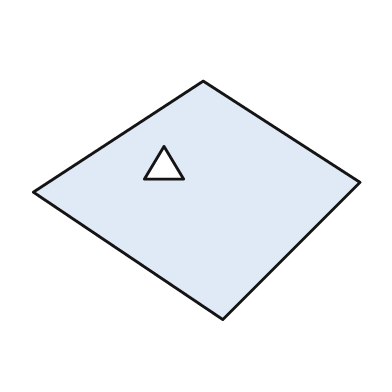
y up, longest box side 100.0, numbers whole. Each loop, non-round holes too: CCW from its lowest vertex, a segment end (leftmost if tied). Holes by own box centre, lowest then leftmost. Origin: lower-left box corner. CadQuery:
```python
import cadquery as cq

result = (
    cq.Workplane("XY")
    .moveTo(58.0, 0.0)
    .lineTo(100.0, 42.0)
    .lineTo(52.0, 73.0)
    .lineTo(0.0, 39.0)
    .close()
    .moveTo(34.0, 43.0)
    .lineTo(46.0, 43.0)
    .lineTo(40.0, 53.0)
    .close()
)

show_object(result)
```